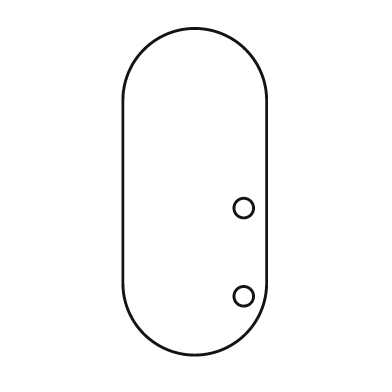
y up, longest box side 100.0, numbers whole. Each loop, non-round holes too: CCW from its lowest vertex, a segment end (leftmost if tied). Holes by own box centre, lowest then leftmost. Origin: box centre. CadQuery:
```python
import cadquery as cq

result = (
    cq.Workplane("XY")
    .moveTo(-22.0, -28.0)
    .threePointArc((0.0, -50.0), (22.0, -28.0))
    .lineTo(22.0, 28.0)
    .threePointArc((0.0, 50.0), (-22.0, 28.0))
    .close()
    .moveTo(15.0, -32.0)
    .circle(3.0)
    .moveTo(15.0, -5.0)
    .circle(3.0)
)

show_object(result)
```